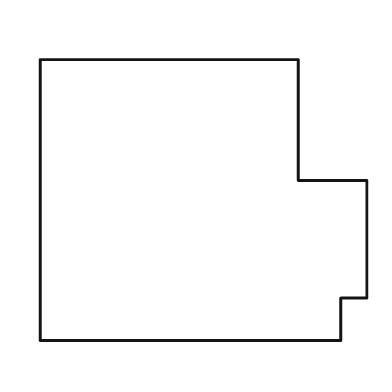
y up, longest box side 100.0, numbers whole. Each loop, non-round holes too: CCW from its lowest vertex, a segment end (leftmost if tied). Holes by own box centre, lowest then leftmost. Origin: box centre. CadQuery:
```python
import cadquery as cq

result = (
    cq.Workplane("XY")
    .moveTo(-50.0, -43.0)
    .lineTo(42.0, -43.0)
    .lineTo(42.0, -30.0)
    .lineTo(50.0, -30.0)
    .lineTo(50.0, 6.0)
    .lineTo(29.0, 6.0)
    .lineTo(29.0, 43.0)
    .lineTo(-50.0, 43.0)
    .close()
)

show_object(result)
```